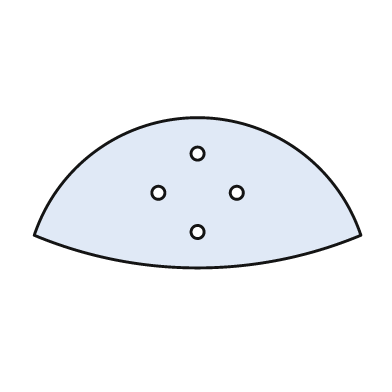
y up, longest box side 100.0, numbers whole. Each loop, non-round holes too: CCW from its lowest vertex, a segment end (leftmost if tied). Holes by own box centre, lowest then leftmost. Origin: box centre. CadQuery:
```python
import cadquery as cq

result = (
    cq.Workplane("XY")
    .moveTo(-50.0, -13.0)
    .threePointArc((0.0, -23.0), (50.0, -13.0))
    .threePointArc((0.0, 23.0), (-50.0, -13.0))
    .close()
    .moveTo(0.0, -12.0)
    .circle(2.0)
    .moveTo(-12.0, 0.0)
    .circle(2.0)
    .moveTo(12.0, 0.0)
    .circle(2.0)
    .moveTo(0.0, 12.0)
    .circle(2.0)
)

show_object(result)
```